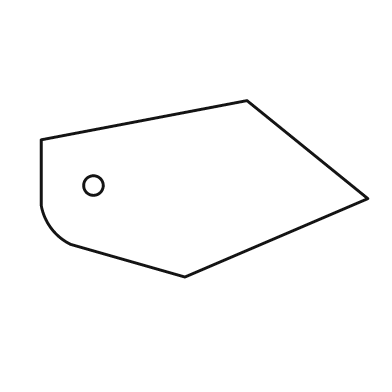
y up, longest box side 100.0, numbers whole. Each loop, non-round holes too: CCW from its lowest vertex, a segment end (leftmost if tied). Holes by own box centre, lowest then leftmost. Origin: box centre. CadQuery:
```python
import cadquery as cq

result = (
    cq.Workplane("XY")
    .moveTo(-6.0, -27.0)
    .lineTo(50.0, -3.0)
    .lineTo(13.0, 27.0)
    .lineTo(-50.0, 15.0)
    .lineTo(-50.0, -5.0)
    .threePointArc((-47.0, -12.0), (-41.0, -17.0))
    .close()
    .moveTo(-34.0, 1.0)
    .circle(3.0)
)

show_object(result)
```